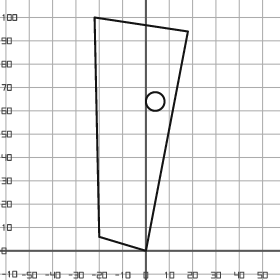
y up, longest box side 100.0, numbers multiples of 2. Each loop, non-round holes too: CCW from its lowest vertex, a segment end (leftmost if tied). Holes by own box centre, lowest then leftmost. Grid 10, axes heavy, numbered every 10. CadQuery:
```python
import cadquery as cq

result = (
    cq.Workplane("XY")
    .moveTo(0.0, 0.0)
    .lineTo(18.0, 94.0)
    .lineTo(-22.0, 100.0)
    .lineTo(-20.0, 6.0)
    .close()
    .moveTo(4.0, 64.0)
    .circle(4.0)
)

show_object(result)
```